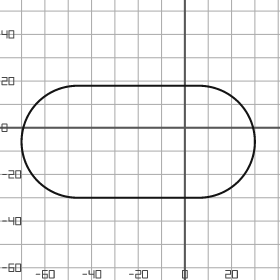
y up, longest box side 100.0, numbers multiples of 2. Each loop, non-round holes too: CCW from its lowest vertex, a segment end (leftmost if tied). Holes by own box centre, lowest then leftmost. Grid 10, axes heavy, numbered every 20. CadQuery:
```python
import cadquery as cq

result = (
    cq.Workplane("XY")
    .moveTo(-46.0, -30.0)
    .lineTo(6.0, -30.0)
    .threePointArc((30.0, -6.0), (6.0, 18.0))
    .lineTo(-46.0, 18.0)
    .threePointArc((-70.0, -6.0), (-46.0, -30.0))
    .close()
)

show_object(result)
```